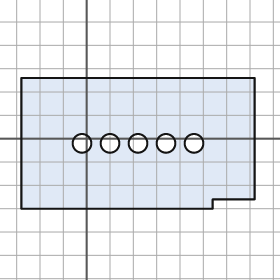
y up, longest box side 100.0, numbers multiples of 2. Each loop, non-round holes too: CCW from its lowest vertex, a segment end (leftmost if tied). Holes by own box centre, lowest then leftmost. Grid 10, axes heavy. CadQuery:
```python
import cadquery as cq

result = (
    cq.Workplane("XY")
    .moveTo(-28.0, -30.0)
    .lineTo(54.0, -30.0)
    .lineTo(54.0, -26.0)
    .lineTo(72.0, -26.0)
    .lineTo(72.0, 26.0)
    .lineTo(-28.0, 26.0)
    .close()
    .moveTo(-2.0, -2.0)
    .circle(4.0)
    .moveTo(10.0, -2.0)
    .circle(4.0)
    .moveTo(22.0, -2.0)
    .circle(4.0)
    .moveTo(34.0, -2.0)
    .circle(4.0)
    .moveTo(46.0, -2.0)
    .circle(4.0)
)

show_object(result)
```